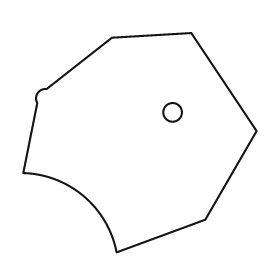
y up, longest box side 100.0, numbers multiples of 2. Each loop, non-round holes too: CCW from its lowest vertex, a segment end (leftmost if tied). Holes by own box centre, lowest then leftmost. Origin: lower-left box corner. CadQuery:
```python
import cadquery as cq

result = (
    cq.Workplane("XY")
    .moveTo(40.0, 0.0)
    .lineTo(78.0, 14.0)
    .lineTo(100.0, 52.0)
    .lineTo(72.0, 94.0)
    .lineTo(38.0, 92.0)
    .lineTo(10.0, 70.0)
    .threePointArc((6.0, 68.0), (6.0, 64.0))
    .lineTo(0.0, 34.0)
    .threePointArc((26.0, 24.0), (40.0, 0.0))
    .close()
    .moveTo(64.0, 60.0)
    .circle(4.0)
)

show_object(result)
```